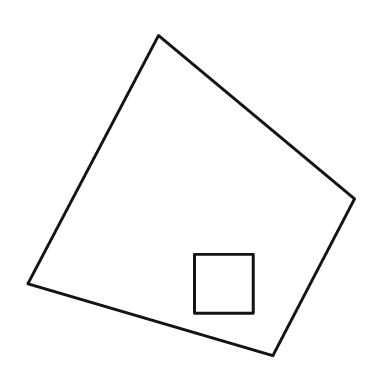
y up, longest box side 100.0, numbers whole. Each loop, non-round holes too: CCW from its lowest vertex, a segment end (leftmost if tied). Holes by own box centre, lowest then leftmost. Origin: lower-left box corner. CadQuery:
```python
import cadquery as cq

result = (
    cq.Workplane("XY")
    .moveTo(75.0, 0.0)
    .lineTo(100.0, 48.0)
    .lineTo(40.0, 98.0)
    .lineTo(0.0, 22.0)
    .close()
    .moveTo(51.0, 13.0)
    .lineTo(69.0, 13.0)
    .lineTo(69.0, 31.0)
    .lineTo(51.0, 31.0)
    .close()
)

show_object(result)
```